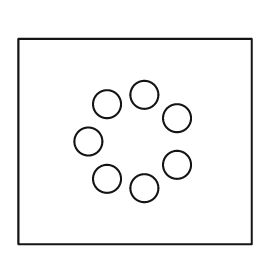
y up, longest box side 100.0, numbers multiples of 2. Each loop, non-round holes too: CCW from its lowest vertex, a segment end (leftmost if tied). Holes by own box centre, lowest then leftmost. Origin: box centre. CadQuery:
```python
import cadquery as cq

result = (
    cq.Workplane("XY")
    .moveTo(-50.0, -44.0)
    .lineTo(50.0, -44.0)
    .lineTo(50.0, 44.0)
    .lineTo(-50.0, 44.0)
    .close()
    .moveTo(4.0, -20.0)
    .circle(6.0)
    .moveTo(-12.0, -16.0)
    .circle(6.0)
    .moveTo(18.0, -10.0)
    .circle(6.0)
    .moveTo(-20.0, 0.0)
    .circle(6.0)
    .moveTo(18.0, 10.0)
    .circle(6.0)
    .moveTo(-12.0, 16.0)
    .circle(6.0)
    .moveTo(4.0, 20.0)
    .circle(6.0)
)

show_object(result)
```